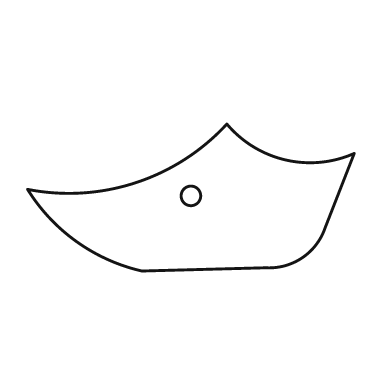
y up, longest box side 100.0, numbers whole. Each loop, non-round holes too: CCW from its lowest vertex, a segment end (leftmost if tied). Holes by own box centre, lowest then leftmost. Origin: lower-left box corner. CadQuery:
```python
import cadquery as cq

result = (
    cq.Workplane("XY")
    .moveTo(35.0, 0.0)
    .lineTo(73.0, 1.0)
    .threePointArc((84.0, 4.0), (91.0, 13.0))
    .lineTo(100.0, 36.0)
    .threePointArc((79.0, 34.0), (61.0, 45.0))
    .threePointArc((33.0, 27.0), (0.0, 25.0))
    .threePointArc((15.0, 9.0), (35.0, 0.0))
    .close()
    .moveTo(50.0, 23.0)
    .circle(3.0)
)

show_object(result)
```